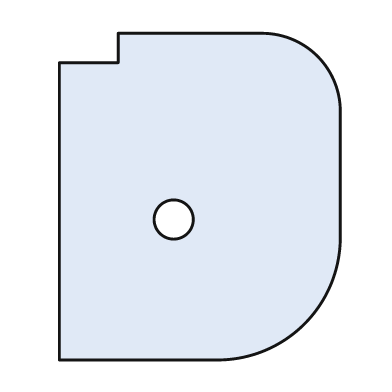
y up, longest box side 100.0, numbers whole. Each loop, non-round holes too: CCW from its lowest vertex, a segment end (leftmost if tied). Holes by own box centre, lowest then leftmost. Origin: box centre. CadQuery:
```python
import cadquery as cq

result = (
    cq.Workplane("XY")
    .moveTo(-43.0, -50.0)
    .lineTo(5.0, -50.0)
    .threePointArc((32.0, -39.0), (43.0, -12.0))
    .lineTo(43.0, 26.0)
    .threePointArc((36.0, 43.0), (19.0, 50.0))
    .lineTo(-25.0, 50.0)
    .lineTo(-25.0, 41.0)
    .lineTo(-43.0, 41.0)
    .close()
    .moveTo(-8.0, -7.0)
    .circle(6.0)
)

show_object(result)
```